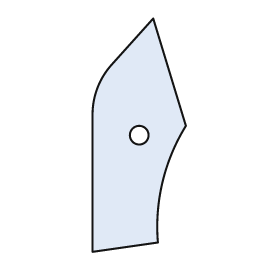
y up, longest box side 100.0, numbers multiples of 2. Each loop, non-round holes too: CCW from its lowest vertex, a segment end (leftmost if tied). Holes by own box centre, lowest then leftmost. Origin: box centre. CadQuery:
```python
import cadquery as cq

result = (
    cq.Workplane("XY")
    .moveTo(-20.0, -50.0)
    .lineTo(8.0, -46.0)
    .threePointArc((10.0, -20.0), (20.0, 4.0))
    .lineTo(6.0, 50.0)
    .lineTo(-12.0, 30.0)
    .threePointArc((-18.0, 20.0), (-20.0, 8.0))
    .close()
    .moveTo(0.0, 0.0)
    .circle(4.0)
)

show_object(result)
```